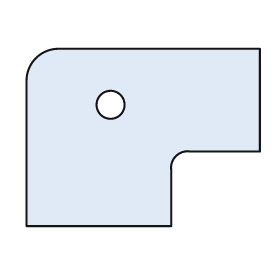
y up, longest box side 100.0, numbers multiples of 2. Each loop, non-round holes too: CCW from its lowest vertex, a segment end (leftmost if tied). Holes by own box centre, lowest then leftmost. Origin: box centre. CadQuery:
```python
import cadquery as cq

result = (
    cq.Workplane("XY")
    .moveTo(-50.0, -38.0)
    .lineTo(12.0, -38.0)
    .lineTo(12.0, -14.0)
    .threePointArc((14.0, -8.0), (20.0, -6.0))
    .lineTo(50.0, -6.0)
    .lineTo(50.0, 38.0)
    .lineTo(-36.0, 38.0)
    .threePointArc((-46.0, 34.0), (-50.0, 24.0))
    .close()
    .moveTo(-14.0, 14.0)
    .circle(6.0)
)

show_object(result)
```